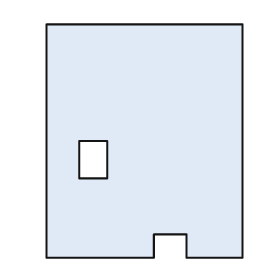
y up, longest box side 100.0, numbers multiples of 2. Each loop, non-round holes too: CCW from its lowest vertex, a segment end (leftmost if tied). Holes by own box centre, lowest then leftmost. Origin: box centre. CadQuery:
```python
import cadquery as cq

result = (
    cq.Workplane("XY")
    .moveTo(-42.0, -50.0)
    .lineTo(4.0, -50.0)
    .lineTo(4.0, -40.0)
    .lineTo(18.0, -40.0)
    .lineTo(18.0, -50.0)
    .lineTo(42.0, -50.0)
    .lineTo(42.0, 50.0)
    .lineTo(-42.0, 50.0)
    .close()
    .moveTo(-28.0, -16.0)
    .lineTo(-16.0, -16.0)
    .lineTo(-16.0, 0.0)
    .lineTo(-28.0, 0.0)
    .close()
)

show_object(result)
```